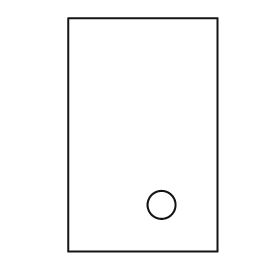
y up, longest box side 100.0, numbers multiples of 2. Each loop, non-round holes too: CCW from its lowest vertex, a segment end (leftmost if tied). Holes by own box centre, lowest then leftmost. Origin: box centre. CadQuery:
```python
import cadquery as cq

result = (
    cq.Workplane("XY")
    .moveTo(-32.0, -50.0)
    .lineTo(32.0, -50.0)
    .lineTo(32.0, 50.0)
    .lineTo(-32.0, 50.0)
    .close()
    .moveTo(8.0, -30.0)
    .circle(6.0)
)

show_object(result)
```